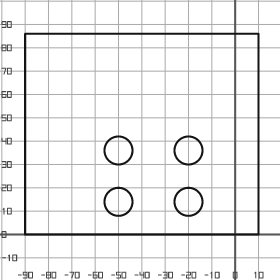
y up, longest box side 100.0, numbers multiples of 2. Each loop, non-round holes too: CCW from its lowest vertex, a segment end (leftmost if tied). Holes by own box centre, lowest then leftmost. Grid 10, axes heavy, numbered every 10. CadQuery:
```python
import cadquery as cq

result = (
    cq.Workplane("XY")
    .moveTo(-90.0, 0.0)
    .lineTo(10.0, 0.0)
    .lineTo(10.0, 86.0)
    .lineTo(-90.0, 86.0)
    .close()
    .moveTo(-50.0, 14.0)
    .circle(6.0)
    .moveTo(-20.0, 14.0)
    .circle(6.0)
    .moveTo(-50.0, 36.0)
    .circle(6.0)
    .moveTo(-20.0, 36.0)
    .circle(6.0)
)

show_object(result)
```